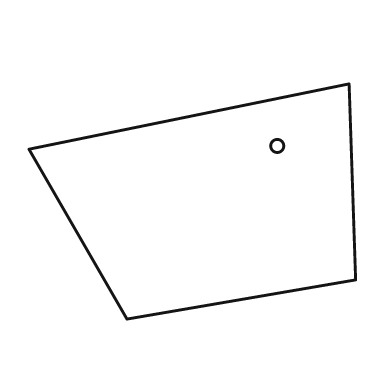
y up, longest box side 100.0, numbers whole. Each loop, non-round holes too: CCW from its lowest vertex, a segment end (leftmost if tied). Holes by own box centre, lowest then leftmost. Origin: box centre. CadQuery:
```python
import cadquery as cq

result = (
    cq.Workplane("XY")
    .moveTo(-20.0, -36.0)
    .lineTo(50.0, -24.0)
    .lineTo(48.0, 36.0)
    .lineTo(-50.0, 16.0)
    .close()
    .moveTo(26.0, 17.0)
    .circle(2.0)
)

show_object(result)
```